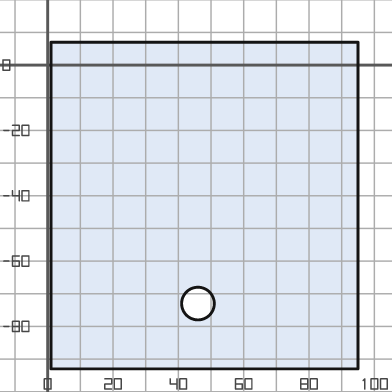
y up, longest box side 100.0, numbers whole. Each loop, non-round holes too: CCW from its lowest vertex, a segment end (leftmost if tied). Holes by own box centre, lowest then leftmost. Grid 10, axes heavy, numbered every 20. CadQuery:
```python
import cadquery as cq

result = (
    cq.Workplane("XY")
    .moveTo(1.0, -93.0)
    .lineTo(95.0, -93.0)
    .lineTo(95.0, 7.0)
    .lineTo(1.0, 7.0)
    .close()
    .moveTo(46.0, -73.0)
    .circle(5.0)
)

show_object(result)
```